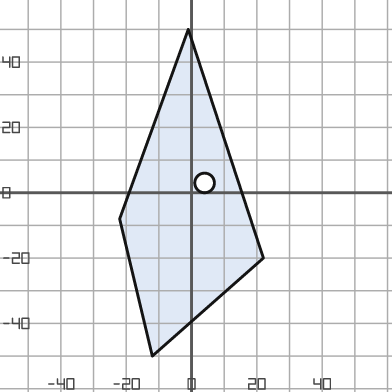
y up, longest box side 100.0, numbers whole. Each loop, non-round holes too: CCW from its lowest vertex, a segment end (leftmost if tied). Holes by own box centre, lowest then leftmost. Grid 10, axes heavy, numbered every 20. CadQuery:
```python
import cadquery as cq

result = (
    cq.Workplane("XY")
    .moveTo(-12.0, -50.0)
    .lineTo(22.0, -20.0)
    .lineTo(-1.0, 50.0)
    .lineTo(-22.0, -8.0)
    .close()
    .moveTo(4.0, 3.0)
    .circle(3.0)
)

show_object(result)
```